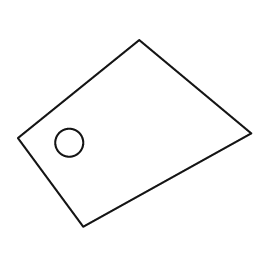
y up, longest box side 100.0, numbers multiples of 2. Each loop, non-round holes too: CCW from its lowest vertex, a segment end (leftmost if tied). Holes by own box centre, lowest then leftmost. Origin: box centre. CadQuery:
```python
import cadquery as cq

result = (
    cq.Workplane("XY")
    .moveTo(-22.0, -40.0)
    .lineTo(50.0, 0.0)
    .lineTo(2.0, 40.0)
    .lineTo(-50.0, -2.0)
    .close()
    .moveTo(-28.0, -4.0)
    .circle(6.0)
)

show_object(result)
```